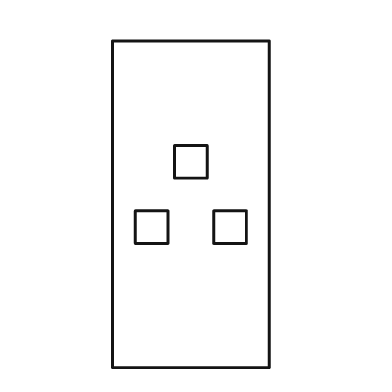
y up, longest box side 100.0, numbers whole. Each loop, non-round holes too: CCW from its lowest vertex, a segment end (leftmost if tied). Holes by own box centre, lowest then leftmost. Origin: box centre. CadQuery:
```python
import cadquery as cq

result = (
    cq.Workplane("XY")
    .moveTo(-24.0, -50.0)
    .lineTo(24.0, -50.0)
    .lineTo(24.0, 50.0)
    .lineTo(-24.0, 50.0)
    .close()
    .moveTo(-17.0, -12.0)
    .lineTo(-7.0, -12.0)
    .lineTo(-7.0, -2.0)
    .lineTo(-17.0, -2.0)
    .close()
    .moveTo(7.0, -12.0)
    .lineTo(17.0, -12.0)
    .lineTo(17.0, -2.0)
    .lineTo(7.0, -2.0)
    .close()
    .moveTo(-5.0, 8.0)
    .lineTo(5.0, 8.0)
    .lineTo(5.0, 18.0)
    .lineTo(-5.0, 18.0)
    .close()
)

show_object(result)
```